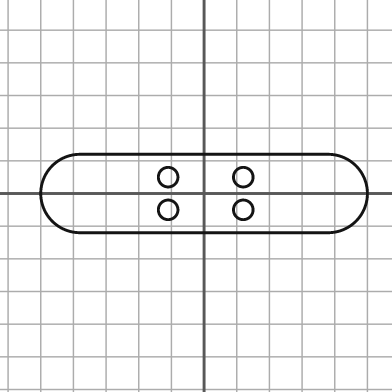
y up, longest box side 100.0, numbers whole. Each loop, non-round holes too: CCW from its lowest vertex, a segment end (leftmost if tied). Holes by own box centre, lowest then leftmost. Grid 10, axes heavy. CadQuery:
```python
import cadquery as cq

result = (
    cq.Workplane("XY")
    .moveTo(-38.0, -12.0)
    .lineTo(38.0, -12.0)
    .threePointArc((50.0, 0.0), (38.0, 12.0))
    .lineTo(-38.0, 12.0)
    .threePointArc((-50.0, 0.0), (-38.0, -12.0))
    .close()
    .moveTo(-11.0, -5.0)
    .circle(3.0)
    .moveTo(12.0, -5.0)
    .circle(3.0)
    .moveTo(-11.0, 5.0)
    .circle(3.0)
    .moveTo(12.0, 5.0)
    .circle(3.0)
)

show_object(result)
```